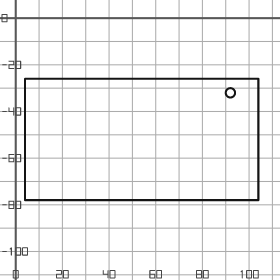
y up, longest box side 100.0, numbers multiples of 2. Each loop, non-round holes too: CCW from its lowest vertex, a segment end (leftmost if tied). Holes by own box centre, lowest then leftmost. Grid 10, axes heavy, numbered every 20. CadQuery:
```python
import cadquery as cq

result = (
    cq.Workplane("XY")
    .moveTo(4.0, -78.0)
    .lineTo(104.0, -78.0)
    .lineTo(104.0, -26.0)
    .lineTo(4.0, -26.0)
    .close()
    .moveTo(92.0, -32.0)
    .circle(2.0)
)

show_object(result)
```